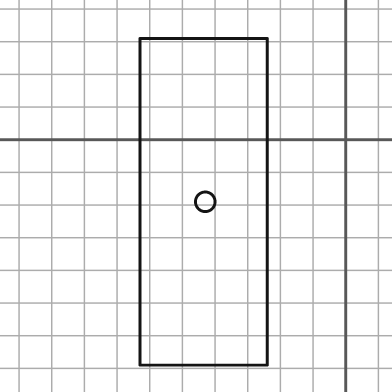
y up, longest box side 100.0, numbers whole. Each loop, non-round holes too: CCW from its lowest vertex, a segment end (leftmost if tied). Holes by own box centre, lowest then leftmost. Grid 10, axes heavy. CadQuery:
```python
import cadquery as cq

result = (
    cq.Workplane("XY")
    .moveTo(-63.0, -69.0)
    .lineTo(-24.0, -69.0)
    .lineTo(-24.0, 31.0)
    .lineTo(-63.0, 31.0)
    .close()
    .moveTo(-43.0, -19.0)
    .circle(3.0)
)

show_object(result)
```